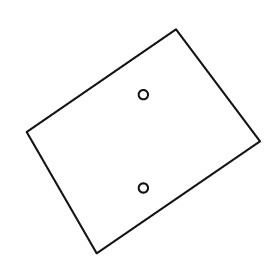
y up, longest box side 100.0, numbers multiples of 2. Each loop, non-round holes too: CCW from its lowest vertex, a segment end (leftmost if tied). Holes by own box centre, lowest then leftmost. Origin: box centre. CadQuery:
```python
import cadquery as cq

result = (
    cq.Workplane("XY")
    .moveTo(-20.0, -48.0)
    .lineTo(50.0, 0.0)
    .lineTo(14.0, 48.0)
    .lineTo(-50.0, 4.0)
    .close()
    .moveTo(0.0, -20.0)
    .circle(2.0)
    .moveTo(0.0, 20.0)
    .circle(2.0)
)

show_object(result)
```